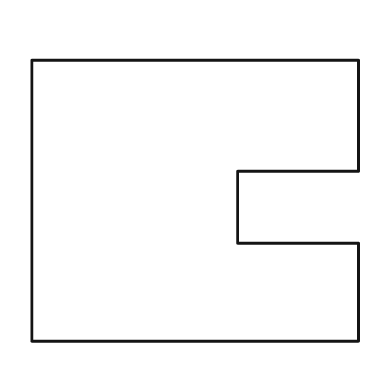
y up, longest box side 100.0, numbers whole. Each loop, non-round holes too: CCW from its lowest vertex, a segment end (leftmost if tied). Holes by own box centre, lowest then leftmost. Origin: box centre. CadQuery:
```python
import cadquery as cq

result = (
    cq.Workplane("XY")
    .moveTo(-50.0, -43.0)
    .lineTo(50.0, -43.0)
    .lineTo(50.0, -13.0)
    .lineTo(13.0, -13.0)
    .lineTo(13.0, 9.0)
    .lineTo(50.0, 9.0)
    .lineTo(50.0, 43.0)
    .lineTo(-50.0, 43.0)
    .close()
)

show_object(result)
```